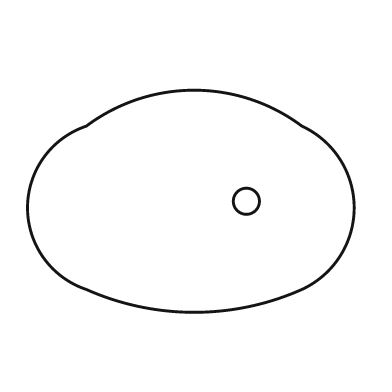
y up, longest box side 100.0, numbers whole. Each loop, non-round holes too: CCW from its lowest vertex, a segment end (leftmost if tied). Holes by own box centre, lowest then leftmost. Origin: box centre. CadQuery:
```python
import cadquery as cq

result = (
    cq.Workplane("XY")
    .moveTo(-32.0, -27.0)
    .threePointArc((1.0, -34.0), (34.0, -27.0))
    .threePointArc((50.0, -2.0), (34.0, 23.0))
    .threePointArc((1.0, 34.0), (-32.0, 23.0))
    .threePointArc((-50.0, -2.0), (-32.0, -27.0))
    .close()
    .moveTo(17.0, 0.0)
    .circle(4.0)
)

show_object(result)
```